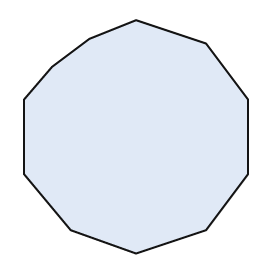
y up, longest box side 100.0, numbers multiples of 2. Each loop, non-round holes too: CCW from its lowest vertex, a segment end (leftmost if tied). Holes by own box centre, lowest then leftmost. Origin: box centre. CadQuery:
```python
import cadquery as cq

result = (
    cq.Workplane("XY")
    .moveTo(0.0, -50.0)
    .lineTo(30.0, -40.0)
    .lineTo(48.0, -16.0)
    .lineTo(48.0, 16.0)
    .lineTo(30.0, 40.0)
    .lineTo(0.0, 50.0)
    .lineTo(-20.0, 42.0)
    .lineTo(-36.0, 30.0)
    .lineTo(-48.0, 16.0)
    .lineTo(-48.0, -16.0)
    .lineTo(-28.0, -40.0)
    .close()
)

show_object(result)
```